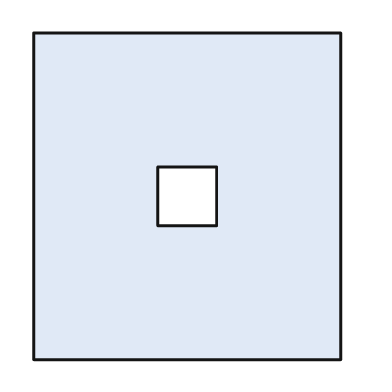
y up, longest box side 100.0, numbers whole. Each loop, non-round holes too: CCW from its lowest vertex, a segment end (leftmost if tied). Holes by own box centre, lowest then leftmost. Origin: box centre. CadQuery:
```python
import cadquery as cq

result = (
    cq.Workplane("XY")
    .moveTo(-47.0, -50.0)
    .lineTo(47.0, -50.0)
    .lineTo(47.0, 50.0)
    .lineTo(-47.0, 50.0)
    .close()
    .moveTo(-9.0, -9.0)
    .lineTo(9.0, -9.0)
    .lineTo(9.0, 9.0)
    .lineTo(-9.0, 9.0)
    .close()
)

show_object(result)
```